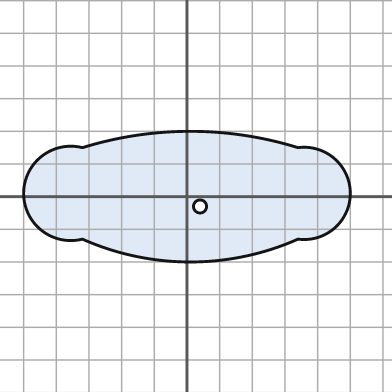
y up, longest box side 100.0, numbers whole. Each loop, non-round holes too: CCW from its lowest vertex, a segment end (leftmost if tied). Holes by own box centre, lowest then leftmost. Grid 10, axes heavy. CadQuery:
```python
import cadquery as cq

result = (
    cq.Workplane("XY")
    .moveTo(-32.0, -13.0)
    .threePointArc((1.0, -20.0), (34.0, -13.0))
    .threePointArc((50.0, 1.0), (34.0, 15.0))
    .threePointArc((1.0, 20.0), (-32.0, 15.0))
    .threePointArc((-50.0, 1.0), (-32.0, -13.0))
    .close()
    .moveTo(4.0, -3.0)
    .circle(2.0)
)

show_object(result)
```